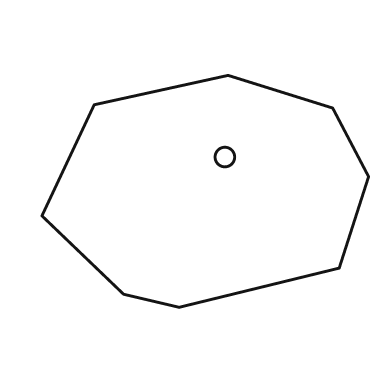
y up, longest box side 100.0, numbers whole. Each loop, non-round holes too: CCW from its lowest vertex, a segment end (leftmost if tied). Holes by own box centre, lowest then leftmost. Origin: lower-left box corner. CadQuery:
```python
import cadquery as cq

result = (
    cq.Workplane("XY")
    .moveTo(42.0, 0.0)
    .lineTo(91.0, 12.0)
    .lineTo(100.0, 40.0)
    .lineTo(89.0, 61.0)
    .lineTo(57.0, 71.0)
    .lineTo(16.0, 62.0)
    .lineTo(0.0, 28.0)
    .lineTo(25.0, 4.0)
    .close()
    .moveTo(56.0, 46.0)
    .circle(3.0)
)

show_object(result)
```